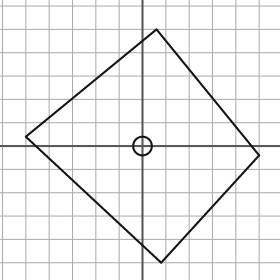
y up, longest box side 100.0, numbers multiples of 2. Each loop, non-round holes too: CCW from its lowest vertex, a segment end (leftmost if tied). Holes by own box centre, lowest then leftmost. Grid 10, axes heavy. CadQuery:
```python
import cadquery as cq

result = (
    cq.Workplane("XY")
    .moveTo(8.0, -50.0)
    .lineTo(50.0, -4.0)
    .lineTo(6.0, 50.0)
    .lineTo(-50.0, 4.0)
    .close()
    .moveTo(0.0, 0.0)
    .circle(4.0)
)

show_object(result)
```